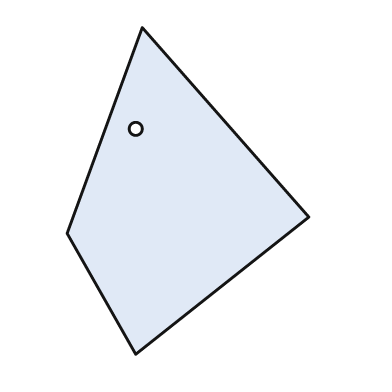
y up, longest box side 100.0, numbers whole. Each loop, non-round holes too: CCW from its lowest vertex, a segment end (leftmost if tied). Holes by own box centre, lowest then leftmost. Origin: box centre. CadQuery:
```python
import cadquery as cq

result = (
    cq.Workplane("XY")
    .moveTo(-16.0, -50.0)
    .lineTo(37.0, -8.0)
    .lineTo(-14.0, 50.0)
    .lineTo(-37.0, -13.0)
    .close()
    .moveTo(-16.0, 19.0)
    .circle(2.0)
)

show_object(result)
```